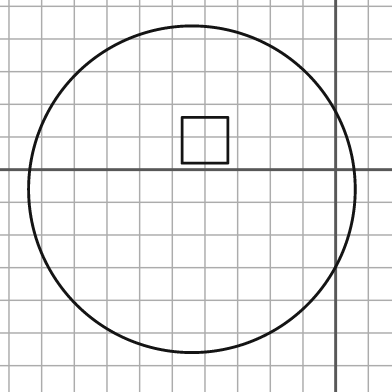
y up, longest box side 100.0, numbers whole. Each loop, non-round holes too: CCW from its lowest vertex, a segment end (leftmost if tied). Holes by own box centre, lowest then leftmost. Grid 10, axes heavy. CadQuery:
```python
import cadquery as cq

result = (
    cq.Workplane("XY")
    .moveTo(-44.0, -6.0)
    .circle(50.0)
    .moveTo(-47.0, 2.0)
    .lineTo(-33.0, 2.0)
    .lineTo(-33.0, 16.0)
    .lineTo(-47.0, 16.0)
    .close()
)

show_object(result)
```